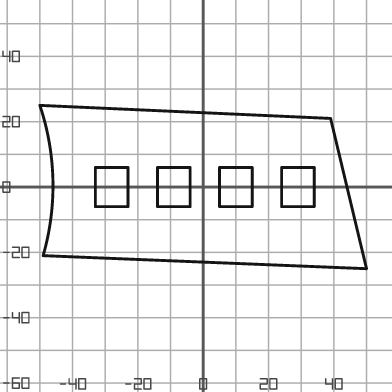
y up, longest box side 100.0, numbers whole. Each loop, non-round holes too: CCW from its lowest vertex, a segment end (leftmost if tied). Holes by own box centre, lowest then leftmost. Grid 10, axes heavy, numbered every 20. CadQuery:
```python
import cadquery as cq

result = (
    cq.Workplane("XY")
    .moveTo(50.0, -25.0)
    .lineTo(39.0, 21.0)
    .lineTo(-50.0, 25.0)
    .threePointArc((-46.0, 2.0), (-49.0, -21.0))
    .close()
    .moveTo(-33.0, -6.0)
    .lineTo(-23.0, -6.0)
    .lineTo(-23.0, 6.0)
    .lineTo(-33.0, 6.0)
    .close()
    .moveTo(-14.0, -6.0)
    .lineTo(-4.0, -6.0)
    .lineTo(-4.0, 6.0)
    .lineTo(-14.0, 6.0)
    .close()
    .moveTo(5.0, -6.0)
    .lineTo(15.0, -6.0)
    .lineTo(15.0, 6.0)
    .lineTo(5.0, 6.0)
    .close()
    .moveTo(24.0, -6.0)
    .lineTo(34.0, -6.0)
    .lineTo(34.0, 6.0)
    .lineTo(24.0, 6.0)
    .close()
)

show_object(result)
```